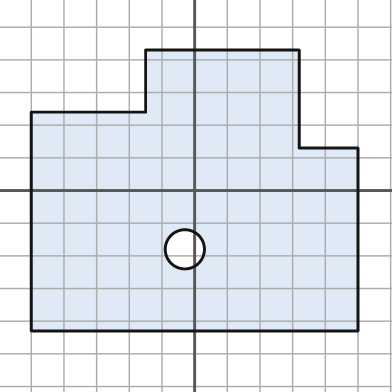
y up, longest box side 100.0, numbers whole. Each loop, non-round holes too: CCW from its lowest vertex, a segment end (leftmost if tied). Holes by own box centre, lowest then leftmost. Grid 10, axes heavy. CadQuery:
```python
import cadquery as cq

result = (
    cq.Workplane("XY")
    .moveTo(-50.0, -43.0)
    .lineTo(50.0, -43.0)
    .lineTo(50.0, 13.0)
    .lineTo(32.0, 13.0)
    .lineTo(32.0, 43.0)
    .lineTo(-15.0, 43.0)
    .lineTo(-15.0, 24.0)
    .lineTo(-50.0, 24.0)
    .close()
    .moveTo(-3.0, -18.0)
    .circle(6.0)
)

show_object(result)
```